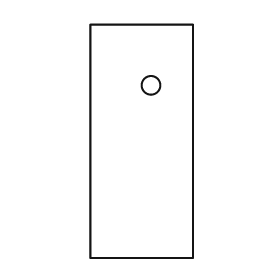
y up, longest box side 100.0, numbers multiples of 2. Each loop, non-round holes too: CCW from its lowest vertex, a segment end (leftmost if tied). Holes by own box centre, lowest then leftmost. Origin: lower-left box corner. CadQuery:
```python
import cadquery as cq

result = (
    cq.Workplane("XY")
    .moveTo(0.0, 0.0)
    .lineTo(44.0, 0.0)
    .lineTo(44.0, 100.0)
    .lineTo(0.0, 100.0)
    .close()
    .moveTo(26.0, 74.0)
    .circle(4.0)
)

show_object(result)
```